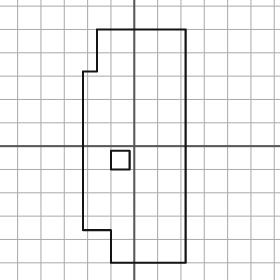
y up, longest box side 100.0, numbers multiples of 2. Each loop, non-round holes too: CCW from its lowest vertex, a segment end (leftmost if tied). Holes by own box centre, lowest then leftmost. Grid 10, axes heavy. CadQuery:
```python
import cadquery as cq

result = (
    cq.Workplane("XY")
    .moveTo(-10.0, -50.0)
    .lineTo(22.0, -50.0)
    .lineTo(22.0, 50.0)
    .lineTo(-16.0, 50.0)
    .lineTo(-16.0, 32.0)
    .lineTo(-22.0, 32.0)
    .lineTo(-22.0, -36.0)
    .lineTo(-10.0, -36.0)
    .close()
    .moveTo(-10.0, -10.0)
    .lineTo(-2.0, -10.0)
    .lineTo(-2.0, -2.0)
    .lineTo(-10.0, -2.0)
    .close()
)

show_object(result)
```